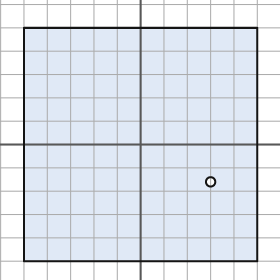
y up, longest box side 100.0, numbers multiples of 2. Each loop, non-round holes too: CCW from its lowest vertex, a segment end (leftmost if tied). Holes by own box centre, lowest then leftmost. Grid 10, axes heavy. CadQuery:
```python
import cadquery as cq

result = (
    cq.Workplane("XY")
    .moveTo(-50.0, -50.0)
    .lineTo(50.0, -50.0)
    .lineTo(50.0, 50.0)
    .lineTo(-50.0, 50.0)
    .close()
    .moveTo(30.0, -16.0)
    .circle(2.0)
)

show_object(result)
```